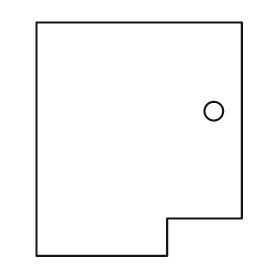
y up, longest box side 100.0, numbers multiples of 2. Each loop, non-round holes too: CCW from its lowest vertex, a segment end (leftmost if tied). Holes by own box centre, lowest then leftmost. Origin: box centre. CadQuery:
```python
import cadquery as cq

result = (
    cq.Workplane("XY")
    .moveTo(-44.0, -50.0)
    .lineTo(12.0, -50.0)
    .lineTo(12.0, -34.0)
    .lineTo(44.0, -34.0)
    .lineTo(44.0, 50.0)
    .lineTo(-44.0, 50.0)
    .close()
    .moveTo(32.0, 12.0)
    .circle(4.0)
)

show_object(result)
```